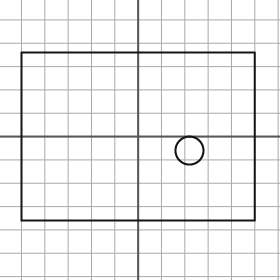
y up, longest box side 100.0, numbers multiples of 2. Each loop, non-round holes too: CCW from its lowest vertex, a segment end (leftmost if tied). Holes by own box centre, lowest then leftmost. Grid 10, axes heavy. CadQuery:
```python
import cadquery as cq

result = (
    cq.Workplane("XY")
    .moveTo(-50.0, -36.0)
    .lineTo(50.0, -36.0)
    .lineTo(50.0, 36.0)
    .lineTo(-50.0, 36.0)
    .close()
    .moveTo(22.0, -6.0)
    .circle(6.0)
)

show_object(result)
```